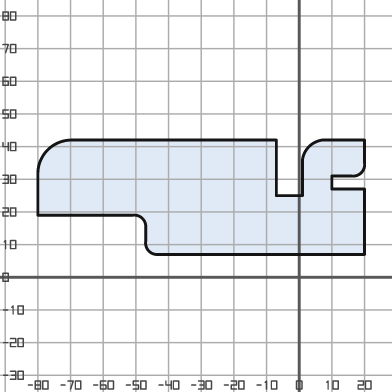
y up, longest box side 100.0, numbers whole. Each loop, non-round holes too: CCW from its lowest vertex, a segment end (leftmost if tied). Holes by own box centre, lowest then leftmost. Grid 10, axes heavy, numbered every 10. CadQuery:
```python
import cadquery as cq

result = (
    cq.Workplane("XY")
    .moveTo(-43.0, 7.0)
    .lineTo(20.0, 7.0)
    .lineTo(20.0, 27.0)
    .lineTo(10.0, 27.0)
    .lineTo(10.0, 31.0)
    .lineTo(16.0, 31.0)
    .threePointArc((19.0, 32.0), (20.0, 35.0))
    .lineTo(20.0, 42.0)
    .lineTo(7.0, 42.0)
    .threePointArc((3.0, 40.0), (1.0, 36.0))
    .lineTo(1.0, 25.0)
    .lineTo(-7.0, 25.0)
    .lineTo(-7.0, 42.0)
    .lineTo(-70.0, 42.0)
    .threePointArc((-77.0, 39.0), (-80.0, 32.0))
    .lineTo(-80.0, 19.0)
    .lineTo(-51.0, 19.0)
    .threePointArc((-48.0, 18.0), (-47.0, 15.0))
    .lineTo(-47.0, 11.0)
    .threePointArc((-46.0, 8.0), (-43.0, 7.0))
    .close()
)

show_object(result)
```